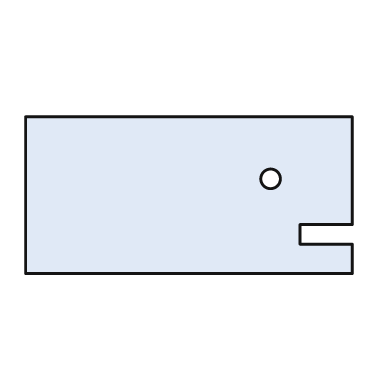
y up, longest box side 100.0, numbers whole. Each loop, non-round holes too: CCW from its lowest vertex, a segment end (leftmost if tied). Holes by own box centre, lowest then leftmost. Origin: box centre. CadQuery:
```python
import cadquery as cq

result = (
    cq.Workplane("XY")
    .moveTo(-50.0, -24.0)
    .lineTo(50.0, -24.0)
    .lineTo(50.0, -15.0)
    .lineTo(34.0, -15.0)
    .lineTo(34.0, -9.0)
    .lineTo(50.0, -9.0)
    .lineTo(50.0, 24.0)
    .lineTo(-50.0, 24.0)
    .close()
    .moveTo(25.0, 5.0)
    .circle(3.0)
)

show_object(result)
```